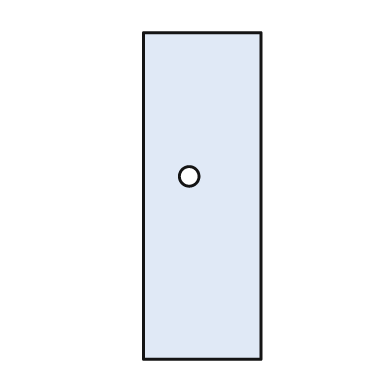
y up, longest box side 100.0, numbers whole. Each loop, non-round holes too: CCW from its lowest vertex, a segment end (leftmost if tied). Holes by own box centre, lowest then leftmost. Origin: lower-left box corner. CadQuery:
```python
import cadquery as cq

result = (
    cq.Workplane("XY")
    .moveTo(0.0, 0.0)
    .lineTo(36.0, 0.0)
    .lineTo(36.0, 100.0)
    .lineTo(0.0, 100.0)
    .close()
    .moveTo(14.0, 56.0)
    .circle(3.0)
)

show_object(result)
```